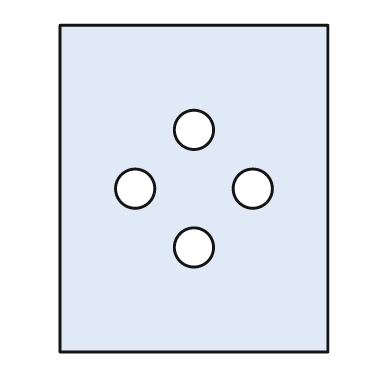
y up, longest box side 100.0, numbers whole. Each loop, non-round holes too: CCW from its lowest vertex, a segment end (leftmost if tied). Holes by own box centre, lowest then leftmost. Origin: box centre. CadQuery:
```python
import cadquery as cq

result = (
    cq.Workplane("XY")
    .moveTo(-41.0, -50.0)
    .lineTo(41.0, -50.0)
    .lineTo(41.0, 50.0)
    .lineTo(-41.0, 50.0)
    .close()
    .moveTo(0.0, -18.0)
    .circle(6.0)
    .moveTo(-18.0, 0.0)
    .circle(6.0)
    .moveTo(18.0, 0.0)
    .circle(6.0)
    .moveTo(0.0, 18.0)
    .circle(6.0)
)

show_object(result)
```